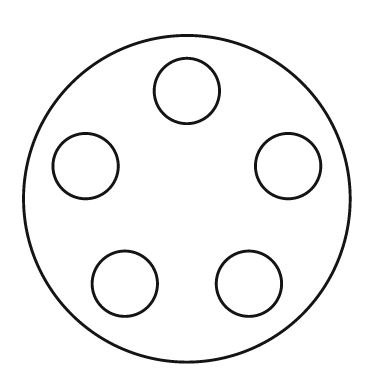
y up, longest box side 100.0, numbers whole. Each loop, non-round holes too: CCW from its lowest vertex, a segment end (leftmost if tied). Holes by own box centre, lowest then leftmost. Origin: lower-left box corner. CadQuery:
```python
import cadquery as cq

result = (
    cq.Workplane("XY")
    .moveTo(50.0, 50.0)
    .circle(50.0)
    .moveTo(31.0, 24.0)
    .circle(10.0)
    .moveTo(69.0, 24.0)
    .circle(10.0)
    .moveTo(19.0, 60.0)
    .circle(10.0)
    .moveTo(81.0, 60.0)
    .circle(10.0)
    .moveTo(50.0, 83.0)
    .circle(10.0)
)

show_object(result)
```